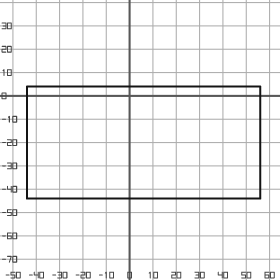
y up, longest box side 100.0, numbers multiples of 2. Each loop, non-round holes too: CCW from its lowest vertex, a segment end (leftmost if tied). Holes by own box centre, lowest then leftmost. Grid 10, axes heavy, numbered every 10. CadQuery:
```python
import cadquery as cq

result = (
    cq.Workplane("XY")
    .moveTo(-44.0, -44.0)
    .lineTo(56.0, -44.0)
    .lineTo(56.0, 4.0)
    .lineTo(-44.0, 4.0)
    .close()
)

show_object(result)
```